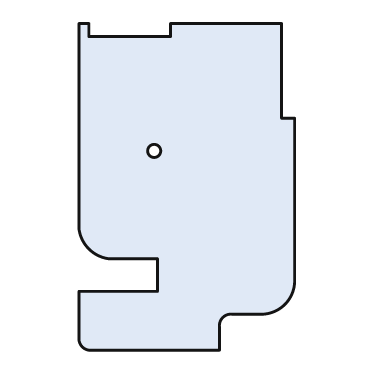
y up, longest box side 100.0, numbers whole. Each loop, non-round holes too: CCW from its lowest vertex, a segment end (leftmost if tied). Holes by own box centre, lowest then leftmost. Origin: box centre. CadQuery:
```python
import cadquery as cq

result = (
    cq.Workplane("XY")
    .moveTo(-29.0, -50.0)
    .lineTo(10.0, -50.0)
    .lineTo(10.0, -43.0)
    .threePointArc((11.0, -40.0), (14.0, -39.0))
    .lineTo(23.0, -39.0)
    .threePointArc((30.0, -36.0), (33.0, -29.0))
    .lineTo(33.0, 21.0)
    .lineTo(29.0, 21.0)
    .lineTo(29.0, 50.0)
    .lineTo(-5.0, 50.0)
    .lineTo(-5.0, 46.0)
    .lineTo(-30.0, 46.0)
    .lineTo(-30.0, 50.0)
    .lineTo(-33.0, 50.0)
    .lineTo(-33.0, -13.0)
    .threePointArc((-30.0, -19.0), (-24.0, -22.0))
    .lineTo(-9.0, -22.0)
    .lineTo(-9.0, -32.0)
    .lineTo(-33.0, -32.0)
    .lineTo(-33.0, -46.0)
    .threePointArc((-32.0, -49.0), (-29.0, -50.0))
    .close()
    .moveTo(-10.0, 11.0)
    .circle(2.0)
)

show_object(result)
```